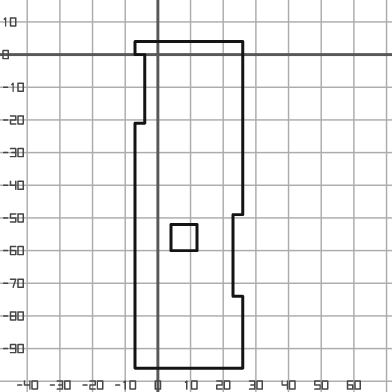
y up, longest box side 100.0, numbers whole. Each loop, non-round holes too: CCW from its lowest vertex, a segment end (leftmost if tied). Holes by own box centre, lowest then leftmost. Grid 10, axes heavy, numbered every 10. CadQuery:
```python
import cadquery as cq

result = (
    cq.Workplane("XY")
    .moveTo(-7.0, -96.0)
    .lineTo(26.0, -96.0)
    .lineTo(26.0, -74.0)
    .lineTo(23.0, -74.0)
    .lineTo(23.0, -49.0)
    .lineTo(26.0, -49.0)
    .lineTo(26.0, 4.0)
    .lineTo(-7.0, 4.0)
    .lineTo(-7.0, 0.0)
    .lineTo(-4.0, 0.0)
    .lineTo(-4.0, -21.0)
    .lineTo(-7.0, -21.0)
    .close()
    .moveTo(4.0, -60.0)
    .lineTo(12.0, -60.0)
    .lineTo(12.0, -52.0)
    .lineTo(4.0, -52.0)
    .close()
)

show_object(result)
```